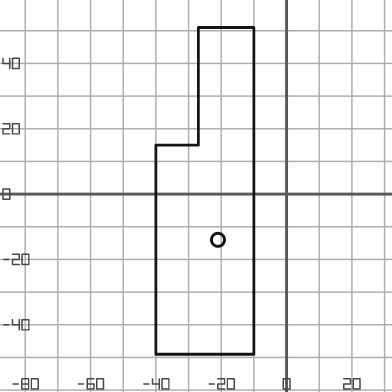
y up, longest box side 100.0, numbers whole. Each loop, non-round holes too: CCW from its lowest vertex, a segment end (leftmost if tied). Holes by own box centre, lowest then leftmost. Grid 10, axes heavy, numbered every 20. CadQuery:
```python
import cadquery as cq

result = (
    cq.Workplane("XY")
    .moveTo(-40.0, -49.0)
    .lineTo(-10.0, -49.0)
    .lineTo(-10.0, 51.0)
    .lineTo(-27.0, 51.0)
    .lineTo(-27.0, 15.0)
    .lineTo(-40.0, 15.0)
    .close()
    .moveTo(-21.0, -14.0)
    .circle(2.0)
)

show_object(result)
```